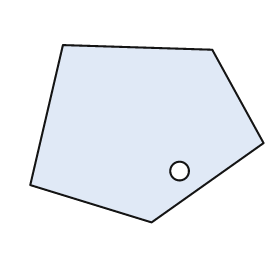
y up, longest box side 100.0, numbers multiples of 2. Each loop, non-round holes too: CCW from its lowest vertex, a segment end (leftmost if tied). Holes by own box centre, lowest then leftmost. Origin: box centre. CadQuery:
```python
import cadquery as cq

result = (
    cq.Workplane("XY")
    .moveTo(2.0, -38.0)
    .lineTo(50.0, -4.0)
    .lineTo(28.0, 36.0)
    .lineTo(-36.0, 38.0)
    .lineTo(-50.0, -22.0)
    .close()
    .moveTo(14.0, -16.0)
    .circle(4.0)
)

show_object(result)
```